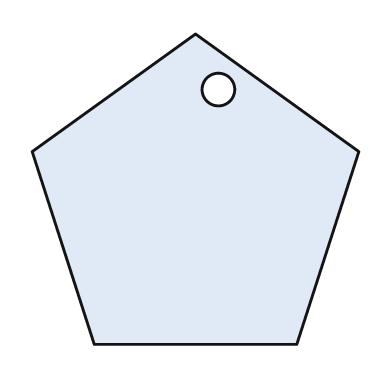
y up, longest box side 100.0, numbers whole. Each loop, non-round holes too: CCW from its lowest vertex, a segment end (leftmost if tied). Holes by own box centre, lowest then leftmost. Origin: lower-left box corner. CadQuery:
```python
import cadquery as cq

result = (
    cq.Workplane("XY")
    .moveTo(19.0, 0.0)
    .lineTo(81.0, 0.0)
    .lineTo(100.0, 59.0)
    .lineTo(50.0, 95.0)
    .lineTo(0.0, 59.0)
    .close()
    .moveTo(57.0, 78.0)
    .circle(5.0)
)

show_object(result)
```